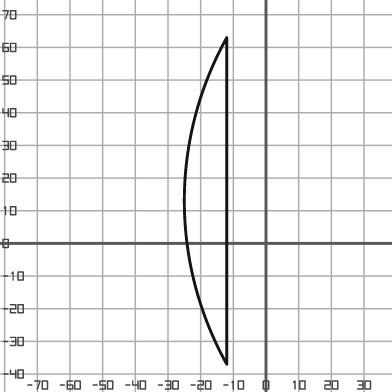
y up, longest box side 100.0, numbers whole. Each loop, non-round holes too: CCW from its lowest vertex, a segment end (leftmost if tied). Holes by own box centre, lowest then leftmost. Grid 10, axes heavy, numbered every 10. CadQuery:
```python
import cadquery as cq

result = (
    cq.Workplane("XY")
    .moveTo(-12.0, -37.0)
    .lineTo(-12.0, 63.0)
    .threePointArc((-25.0, 13.0), (-12.0, -37.0))
    .close()
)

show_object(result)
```